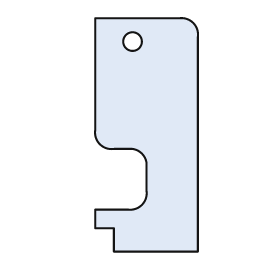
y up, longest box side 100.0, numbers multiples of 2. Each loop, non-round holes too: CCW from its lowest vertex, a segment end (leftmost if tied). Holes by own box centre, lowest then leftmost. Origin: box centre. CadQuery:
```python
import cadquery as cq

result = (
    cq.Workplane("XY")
    .moveTo(-14.0, -50.0)
    .lineTo(22.0, -50.0)
    .lineTo(22.0, 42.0)
    .threePointArc((20.0, 48.0), (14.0, 50.0))
    .lineTo(-22.0, 50.0)
    .lineTo(-22.0, 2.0)
    .threePointArc((-20.0, -4.0), (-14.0, -6.0))
    .lineTo(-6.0, -6.0)
    .threePointArc((-2.0, -8.0), (0.0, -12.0))
    .lineTo(0.0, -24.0)
    .threePointArc((-2.0, -30.0), (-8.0, -32.0))
    .lineTo(-22.0, -32.0)
    .lineTo(-22.0, -40.0)
    .lineTo(-14.0, -40.0)
    .close()
    .moveTo(-6.0, 40.0)
    .circle(4.0)
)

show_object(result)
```